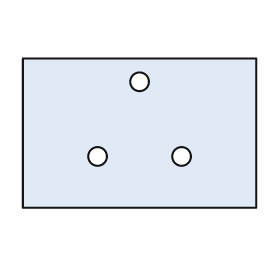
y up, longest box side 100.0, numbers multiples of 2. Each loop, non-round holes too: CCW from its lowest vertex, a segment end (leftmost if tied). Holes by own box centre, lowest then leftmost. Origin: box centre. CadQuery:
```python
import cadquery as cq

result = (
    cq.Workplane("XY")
    .moveTo(-50.0, -32.0)
    .lineTo(50.0, -32.0)
    .lineTo(50.0, 32.0)
    .lineTo(-50.0, 32.0)
    .close()
    .moveTo(-18.0, -10.0)
    .circle(4.0)
    .moveTo(18.0, -10.0)
    .circle(4.0)
    .moveTo(0.0, 22.0)
    .circle(4.0)
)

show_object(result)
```